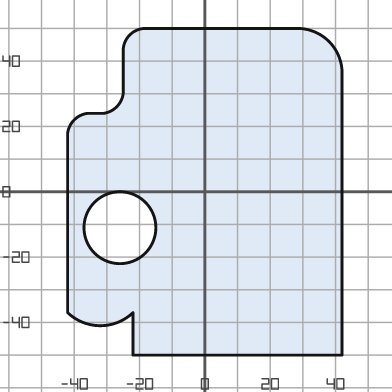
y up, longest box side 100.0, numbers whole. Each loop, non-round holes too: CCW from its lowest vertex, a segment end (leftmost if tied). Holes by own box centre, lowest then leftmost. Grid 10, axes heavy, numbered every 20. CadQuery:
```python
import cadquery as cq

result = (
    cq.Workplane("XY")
    .moveTo(-22.0, -50.0)
    .lineTo(42.0, -50.0)
    .lineTo(42.0, 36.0)
    .threePointArc((38.0, 46.0), (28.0, 50.0))
    .lineTo(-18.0, 50.0)
    .threePointArc((-23.0, 48.0), (-25.0, 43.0))
    .lineTo(-25.0, 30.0)
    .threePointArc((-27.0, 26.0), (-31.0, 24.0))
    .lineTo(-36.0, 24.0)
    .threePointArc((-40.0, 22.0), (-42.0, 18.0))
    .lineTo(-42.0, -37.0)
    .threePointArc((-32.0, -41.0), (-22.0, -37.0))
    .close()
    .moveTo(-26.0, -11.0)
    .circle(11.0)
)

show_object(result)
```